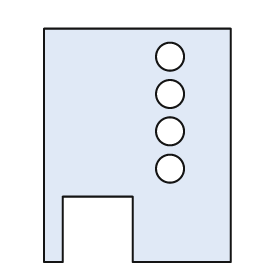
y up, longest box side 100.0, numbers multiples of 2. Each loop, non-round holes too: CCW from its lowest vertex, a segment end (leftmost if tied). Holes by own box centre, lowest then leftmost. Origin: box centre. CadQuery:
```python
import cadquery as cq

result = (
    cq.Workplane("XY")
    .moveTo(-40.0, -50.0)
    .lineTo(-32.0, -50.0)
    .lineTo(-32.0, -22.0)
    .lineTo(-2.0, -22.0)
    .lineTo(-2.0, -50.0)
    .lineTo(40.0, -50.0)
    .lineTo(40.0, 50.0)
    .lineTo(-40.0, 50.0)
    .close()
    .moveTo(14.0, -10.0)
    .circle(6.0)
    .moveTo(14.0, 6.0)
    .circle(6.0)
    .moveTo(14.0, 22.0)
    .circle(6.0)
    .moveTo(14.0, 38.0)
    .circle(6.0)
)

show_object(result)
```